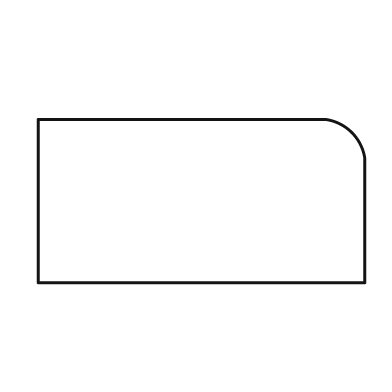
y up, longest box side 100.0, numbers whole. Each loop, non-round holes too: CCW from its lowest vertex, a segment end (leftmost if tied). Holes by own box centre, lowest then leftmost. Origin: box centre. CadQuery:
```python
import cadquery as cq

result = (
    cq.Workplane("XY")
    .moveTo(-50.0, -25.0)
    .lineTo(50.0, -25.0)
    .lineTo(50.0, 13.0)
    .threePointArc((46.0, 21.0), (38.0, 25.0))
    .lineTo(-50.0, 25.0)
    .close()
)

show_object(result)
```